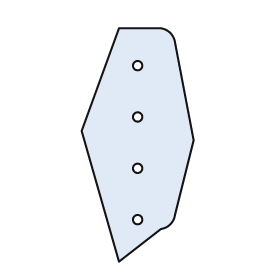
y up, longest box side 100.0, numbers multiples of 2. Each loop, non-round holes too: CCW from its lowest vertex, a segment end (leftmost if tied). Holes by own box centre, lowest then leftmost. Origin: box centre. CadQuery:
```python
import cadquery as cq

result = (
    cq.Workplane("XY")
    .moveTo(-8.0, -50.0)
    .lineTo(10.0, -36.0)
    .threePointArc((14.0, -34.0), (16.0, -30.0))
    .lineTo(24.0, 2.0)
    .lineTo(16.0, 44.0)
    .threePointArc((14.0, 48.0), (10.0, 50.0))
    .lineTo(-8.0, 50.0)
    .lineTo(-24.0, 6.0)
    .close()
    .moveTo(0.0, -32.0)
    .circle(2.0)
    .moveTo(0.0, -10.0)
    .circle(2.0)
    .moveTo(0.0, 12.0)
    .circle(2.0)
    .moveTo(0.0, 34.0)
    .circle(2.0)
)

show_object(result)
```